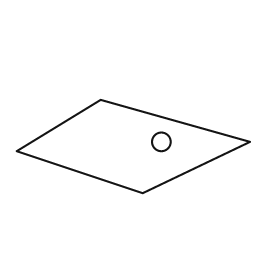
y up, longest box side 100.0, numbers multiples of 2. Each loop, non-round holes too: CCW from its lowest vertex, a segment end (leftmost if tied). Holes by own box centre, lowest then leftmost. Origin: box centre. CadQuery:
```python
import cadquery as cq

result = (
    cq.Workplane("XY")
    .moveTo(4.0, -20.0)
    .lineTo(50.0, 2.0)
    .lineTo(-14.0, 20.0)
    .lineTo(-50.0, -2.0)
    .close()
    .moveTo(12.0, 2.0)
    .circle(4.0)
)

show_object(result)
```